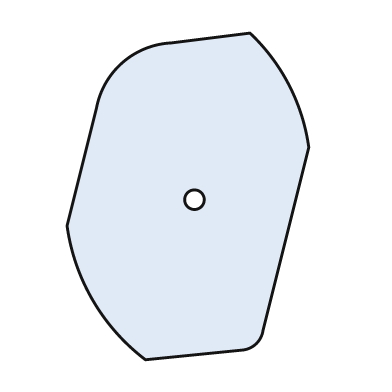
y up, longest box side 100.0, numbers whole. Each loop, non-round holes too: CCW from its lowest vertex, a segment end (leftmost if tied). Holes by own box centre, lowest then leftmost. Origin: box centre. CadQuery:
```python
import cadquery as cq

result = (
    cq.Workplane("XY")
    .moveTo(-13.0, -50.0)
    .lineTo(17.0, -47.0)
    .threePointArc((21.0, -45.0), (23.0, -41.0))
    .lineTo(37.0, 15.0)
    .threePointArc((31.0, 34.0), (19.0, 50.0))
    .lineTo(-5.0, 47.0)
    .threePointArc((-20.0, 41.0), (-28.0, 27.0))
    .lineTo(-37.0, -9.0)
    .threePointArc((-29.0, -32.0), (-13.0, -50.0))
    .close()
    .moveTo(2.0, -1.0)
    .circle(3.0)
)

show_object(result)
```